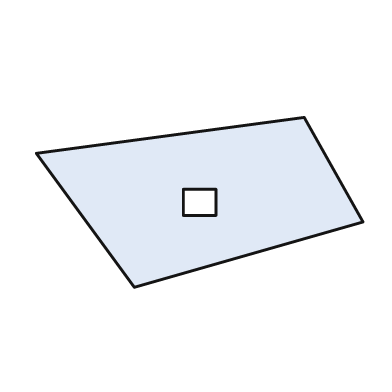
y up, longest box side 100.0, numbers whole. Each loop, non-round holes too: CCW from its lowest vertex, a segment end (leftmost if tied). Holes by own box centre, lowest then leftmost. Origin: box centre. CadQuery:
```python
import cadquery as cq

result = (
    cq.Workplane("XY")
    .moveTo(-20.0, -26.0)
    .lineTo(50.0, -6.0)
    .lineTo(32.0, 26.0)
    .lineTo(-50.0, 15.0)
    .close()
    .moveTo(-5.0, -4.0)
    .lineTo(5.0, -4.0)
    .lineTo(5.0, 4.0)
    .lineTo(-5.0, 4.0)
    .close()
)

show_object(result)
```